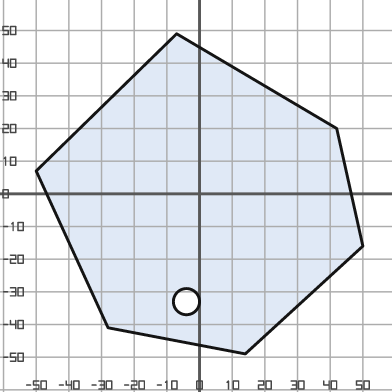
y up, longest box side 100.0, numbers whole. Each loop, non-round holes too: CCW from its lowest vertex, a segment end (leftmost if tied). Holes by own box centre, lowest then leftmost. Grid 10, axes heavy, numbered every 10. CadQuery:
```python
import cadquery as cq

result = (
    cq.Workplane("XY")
    .moveTo(14.0, -49.0)
    .lineTo(50.0, -16.0)
    .lineTo(42.0, 20.0)
    .lineTo(-7.0, 49.0)
    .lineTo(-50.0, 7.0)
    .lineTo(-28.0, -41.0)
    .close()
    .moveTo(-4.0, -33.0)
    .circle(4.0)
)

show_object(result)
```